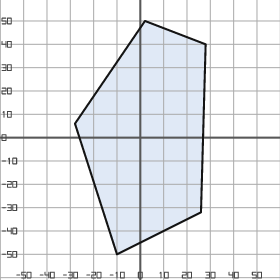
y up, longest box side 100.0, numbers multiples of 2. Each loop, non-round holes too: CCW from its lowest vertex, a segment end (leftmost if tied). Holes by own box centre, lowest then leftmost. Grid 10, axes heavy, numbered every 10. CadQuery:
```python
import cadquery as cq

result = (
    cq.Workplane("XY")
    .moveTo(-10.0, -50.0)
    .lineTo(26.0, -32.0)
    .lineTo(28.0, 40.0)
    .lineTo(2.0, 50.0)
    .lineTo(-28.0, 6.0)
    .close()
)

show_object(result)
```